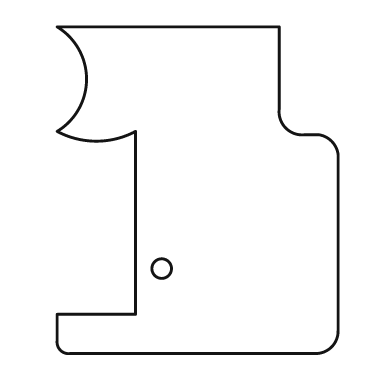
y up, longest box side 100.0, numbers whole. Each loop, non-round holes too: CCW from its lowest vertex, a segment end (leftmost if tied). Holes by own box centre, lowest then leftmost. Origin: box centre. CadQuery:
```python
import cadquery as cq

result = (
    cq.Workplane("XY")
    .moveTo(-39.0, -50.0)
    .lineTo(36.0, -50.0)
    .threePointArc((41.0, -48.0), (43.0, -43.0))
    .lineTo(43.0, 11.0)
    .threePointArc((41.0, 15.0), (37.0, 17.0))
    .lineTo(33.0, 17.0)
    .threePointArc((27.0, 19.0), (25.0, 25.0))
    .lineTo(25.0, 50.0)
    .lineTo(-43.0, 50.0)
    .threePointArc((-34.0, 34.0), (-43.0, 18.0))
    .threePointArc((-31.0, 15.0), (-19.0, 18.0))
    .lineTo(-19.0, -38.0)
    .lineTo(-43.0, -38.0)
    .lineTo(-43.0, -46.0)
    .threePointArc((-42.0, -49.0), (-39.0, -50.0))
    .close()
    .moveTo(-11.0, -24.0)
    .circle(3.0)
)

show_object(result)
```